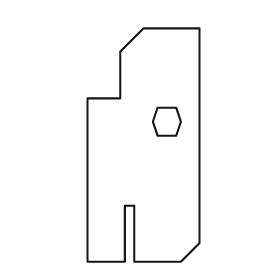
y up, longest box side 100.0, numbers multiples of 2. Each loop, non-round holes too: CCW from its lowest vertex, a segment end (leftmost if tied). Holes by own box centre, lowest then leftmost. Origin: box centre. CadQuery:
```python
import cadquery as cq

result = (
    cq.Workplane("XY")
    .moveTo(-24.0, -50.0)
    .lineTo(-8.0, -50.0)
    .lineTo(-8.0, -26.0)
    .lineTo(-4.0, -26.0)
    .lineTo(-4.0, -50.0)
    .lineTo(16.0, -50.0)
    .lineTo(24.0, -42.0)
    .lineTo(24.0, 50.0)
    .lineTo(0.0, 50.0)
    .lineTo(-10.0, 40.0)
    .lineTo(-10.0, 20.0)
    .lineTo(-24.0, 20.0)
    .close()
    .moveTo(6.0, 4.0)
    .lineTo(14.0, 4.0)
    .lineTo(16.0, 10.0)
    .lineTo(14.0, 16.0)
    .lineTo(6.0, 16.0)
    .lineTo(4.0, 10.0)
    .close()
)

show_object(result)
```